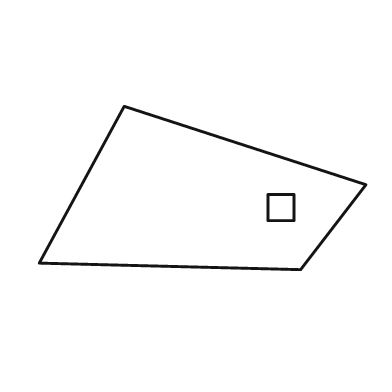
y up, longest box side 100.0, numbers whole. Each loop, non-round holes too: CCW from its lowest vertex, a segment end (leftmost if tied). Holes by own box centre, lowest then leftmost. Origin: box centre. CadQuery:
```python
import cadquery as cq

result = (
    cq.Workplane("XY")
    .moveTo(30.0, -25.0)
    .lineTo(50.0, 1.0)
    .lineTo(-24.0, 25.0)
    .lineTo(-50.0, -23.0)
    .close()
    .moveTo(20.0, -10.0)
    .lineTo(28.0, -10.0)
    .lineTo(28.0, -2.0)
    .lineTo(20.0, -2.0)
    .close()
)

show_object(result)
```